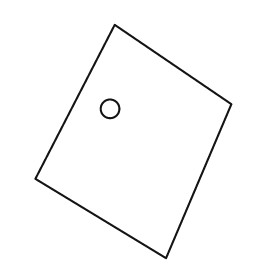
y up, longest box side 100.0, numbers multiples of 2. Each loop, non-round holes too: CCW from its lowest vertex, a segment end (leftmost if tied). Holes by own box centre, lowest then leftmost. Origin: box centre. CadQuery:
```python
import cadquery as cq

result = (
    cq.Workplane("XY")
    .moveTo(14.0, -50.0)
    .lineTo(42.0, 16.0)
    .lineTo(-8.0, 50.0)
    .lineTo(-42.0, -16.0)
    .close()
    .moveTo(-10.0, 14.0)
    .circle(4.0)
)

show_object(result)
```